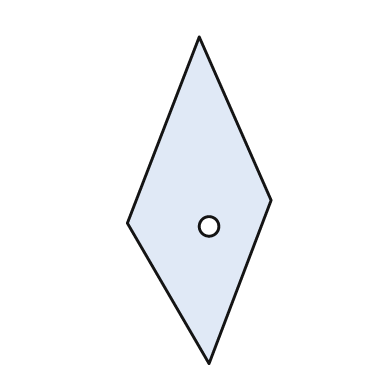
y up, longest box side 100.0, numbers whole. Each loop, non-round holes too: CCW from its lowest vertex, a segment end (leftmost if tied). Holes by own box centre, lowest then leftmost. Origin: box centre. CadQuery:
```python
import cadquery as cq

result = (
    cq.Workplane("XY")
    .moveTo(3.0, -50.0)
    .lineTo(22.0, 0.0)
    .lineTo(0.0, 50.0)
    .lineTo(-22.0, -7.0)
    .close()
    .moveTo(3.0, -8.0)
    .circle(3.0)
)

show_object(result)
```